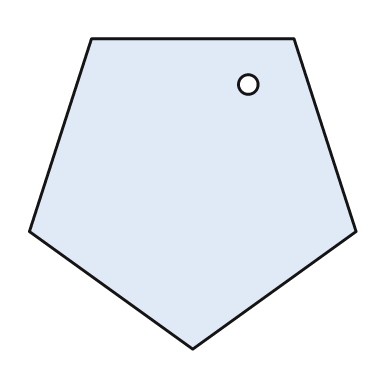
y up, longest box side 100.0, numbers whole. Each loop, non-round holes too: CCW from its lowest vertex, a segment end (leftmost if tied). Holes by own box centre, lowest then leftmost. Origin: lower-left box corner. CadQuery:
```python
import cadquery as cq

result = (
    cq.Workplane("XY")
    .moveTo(50.0, 0.0)
    .lineTo(100.0, 36.0)
    .lineTo(81.0, 95.0)
    .lineTo(19.0, 95.0)
    .lineTo(0.0, 36.0)
    .close()
    .moveTo(67.0, 81.0)
    .circle(3.0)
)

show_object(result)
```